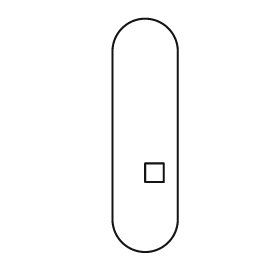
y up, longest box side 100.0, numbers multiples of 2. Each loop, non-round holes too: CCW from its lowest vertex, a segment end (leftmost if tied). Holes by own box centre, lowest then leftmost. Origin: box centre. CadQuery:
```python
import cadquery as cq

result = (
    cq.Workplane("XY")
    .moveTo(-14.0, -36.0)
    .threePointArc((0.0, -50.0), (14.0, -36.0))
    .lineTo(14.0, 36.0)
    .threePointArc((0.0, 50.0), (-14.0, 36.0))
    .close()
    .moveTo(0.0, -20.0)
    .lineTo(8.0, -20.0)
    .lineTo(8.0, -12.0)
    .lineTo(0.0, -12.0)
    .close()
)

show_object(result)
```